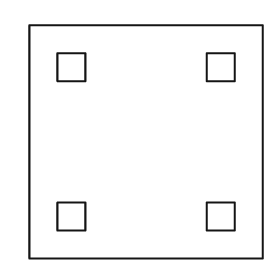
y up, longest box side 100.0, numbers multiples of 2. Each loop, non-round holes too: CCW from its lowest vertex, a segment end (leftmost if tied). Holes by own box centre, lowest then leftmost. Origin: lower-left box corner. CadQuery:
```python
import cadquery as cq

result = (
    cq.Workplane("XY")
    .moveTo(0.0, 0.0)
    .lineTo(100.0, 0.0)
    .lineTo(100.0, 100.0)
    .lineTo(0.0, 100.0)
    .close()
    .moveTo(12.0, 12.0)
    .lineTo(24.0, 12.0)
    .lineTo(24.0, 24.0)
    .lineTo(12.0, 24.0)
    .close()
    .moveTo(76.0, 12.0)
    .lineTo(88.0, 12.0)
    .lineTo(88.0, 24.0)
    .lineTo(76.0, 24.0)
    .close()
    .moveTo(12.0, 76.0)
    .lineTo(24.0, 76.0)
    .lineTo(24.0, 88.0)
    .lineTo(12.0, 88.0)
    .close()
    .moveTo(76.0, 76.0)
    .lineTo(88.0, 76.0)
    .lineTo(88.0, 88.0)
    .lineTo(76.0, 88.0)
    .close()
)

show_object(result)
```